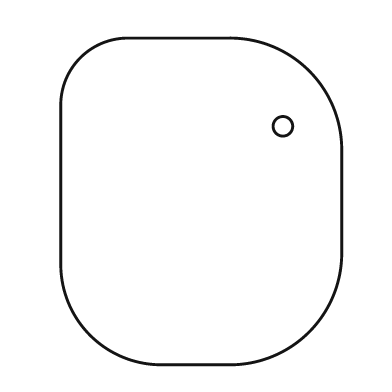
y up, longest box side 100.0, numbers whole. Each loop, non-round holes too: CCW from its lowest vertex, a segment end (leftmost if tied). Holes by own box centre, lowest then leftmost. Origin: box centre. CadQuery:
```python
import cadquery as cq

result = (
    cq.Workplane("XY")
    .moveTo(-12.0, -50.0)
    .lineTo(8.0, -50.0)
    .threePointArc((33.0, -40.0), (43.0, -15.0))
    .lineTo(43.0, 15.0)
    .threePointArc((33.0, 40.0), (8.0, 50.0))
    .lineTo(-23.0, 50.0)
    .threePointArc((-37.0, 44.0), (-43.0, 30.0))
    .lineTo(-43.0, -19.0)
    .threePointArc((-34.0, -41.0), (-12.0, -50.0))
    .close()
    .moveTo(25.0, 23.0)
    .circle(3.0)
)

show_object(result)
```